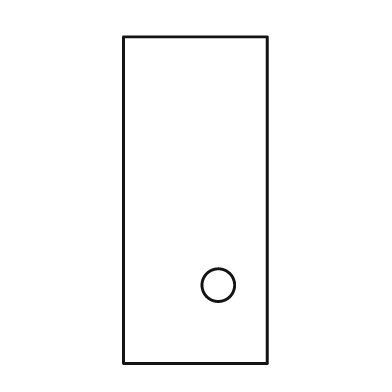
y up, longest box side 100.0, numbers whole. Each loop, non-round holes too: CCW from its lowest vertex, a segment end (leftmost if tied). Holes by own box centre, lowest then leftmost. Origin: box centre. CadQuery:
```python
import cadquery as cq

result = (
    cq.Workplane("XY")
    .moveTo(-22.0, -50.0)
    .lineTo(22.0, -50.0)
    .lineTo(22.0, 50.0)
    .lineTo(-22.0, 50.0)
    .close()
    .moveTo(7.0, -26.0)
    .circle(5.0)
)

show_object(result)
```